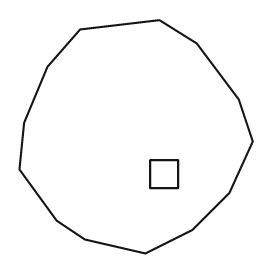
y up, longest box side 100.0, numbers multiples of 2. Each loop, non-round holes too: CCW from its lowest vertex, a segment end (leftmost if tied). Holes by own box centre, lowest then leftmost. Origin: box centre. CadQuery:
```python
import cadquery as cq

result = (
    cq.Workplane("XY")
    .moveTo(4.0, -50.0)
    .lineTo(24.0, -40.0)
    .lineTo(40.0, -24.0)
    .lineTo(50.0, -2.0)
    .lineTo(44.0, 16.0)
    .lineTo(26.0, 40.0)
    .lineTo(10.0, 50.0)
    .lineTo(-24.0, 46.0)
    .lineTo(-38.0, 30.0)
    .lineTo(-48.0, 6.0)
    .lineTo(-50.0, -14.0)
    .lineTo(-34.0, -36.0)
    .lineTo(-22.0, -44.0)
    .close()
    .moveTo(6.0, -22.0)
    .lineTo(18.0, -22.0)
    .lineTo(18.0, -10.0)
    .lineTo(6.0, -10.0)
    .close()
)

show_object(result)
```